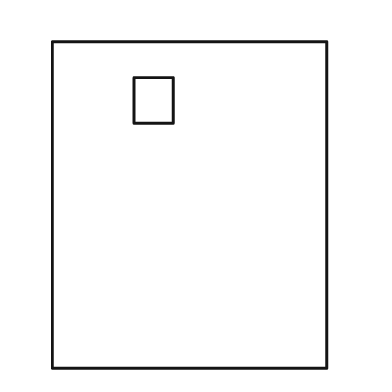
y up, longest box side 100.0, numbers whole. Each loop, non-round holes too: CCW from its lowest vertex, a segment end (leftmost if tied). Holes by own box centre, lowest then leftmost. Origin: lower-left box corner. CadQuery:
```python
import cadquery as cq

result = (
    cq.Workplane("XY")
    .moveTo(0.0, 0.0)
    .lineTo(84.0, 0.0)
    .lineTo(84.0, 100.0)
    .lineTo(0.0, 100.0)
    .close()
    .moveTo(25.0, 75.0)
    .lineTo(37.0, 75.0)
    .lineTo(37.0, 89.0)
    .lineTo(25.0, 89.0)
    .close()
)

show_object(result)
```